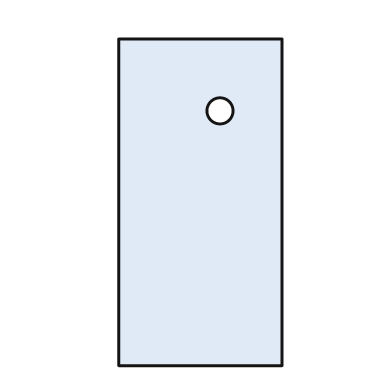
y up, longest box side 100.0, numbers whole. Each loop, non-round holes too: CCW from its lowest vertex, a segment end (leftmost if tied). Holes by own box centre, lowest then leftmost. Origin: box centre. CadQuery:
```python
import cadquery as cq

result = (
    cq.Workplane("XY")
    .moveTo(-25.0, -50.0)
    .lineTo(25.0, -50.0)
    .lineTo(25.0, 50.0)
    .lineTo(-25.0, 50.0)
    .close()
    .moveTo(6.0, 28.0)
    .circle(4.0)
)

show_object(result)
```